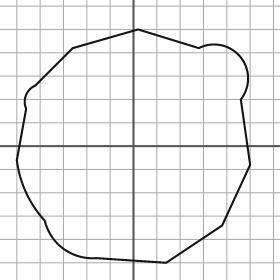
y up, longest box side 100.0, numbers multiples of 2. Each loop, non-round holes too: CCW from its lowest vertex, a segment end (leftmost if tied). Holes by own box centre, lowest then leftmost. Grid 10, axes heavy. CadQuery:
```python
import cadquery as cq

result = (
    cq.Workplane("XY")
    .moveTo(14.0, -50.0)
    .lineTo(38.0, -34.0)
    .lineTo(50.0, -8.0)
    .lineTo(46.0, 20.0)
    .threePointArc((46.0, 38.0), (28.0, 42.0))
    .lineTo(2.0, 50.0)
    .lineTo(-26.0, 42.0)
    .lineTo(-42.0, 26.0)
    .threePointArc((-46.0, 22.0), (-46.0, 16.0))
    .lineTo(-50.0, -6.0)
    .threePointArc((-46.0, -20.0), (-38.0, -32.0))
    .threePointArc((-30.0, -44.0), (-16.0, -48.0))
    .close()
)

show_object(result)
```